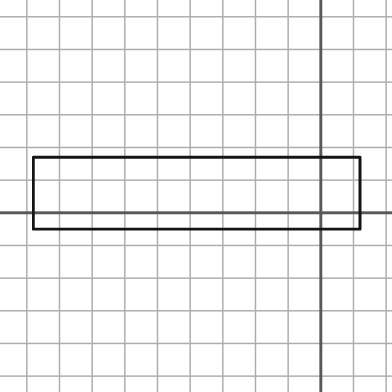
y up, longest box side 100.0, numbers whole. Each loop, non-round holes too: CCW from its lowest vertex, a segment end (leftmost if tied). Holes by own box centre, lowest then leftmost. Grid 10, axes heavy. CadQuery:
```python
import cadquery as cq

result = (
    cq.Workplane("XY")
    .moveTo(-88.0, -5.0)
    .lineTo(12.0, -5.0)
    .lineTo(12.0, 17.0)
    .lineTo(-88.0, 17.0)
    .close()
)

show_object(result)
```